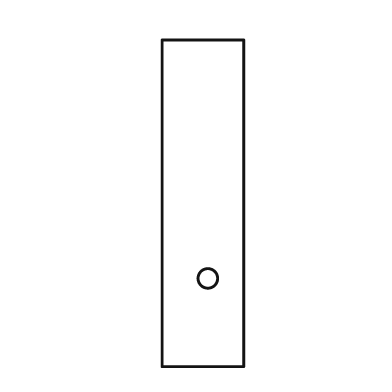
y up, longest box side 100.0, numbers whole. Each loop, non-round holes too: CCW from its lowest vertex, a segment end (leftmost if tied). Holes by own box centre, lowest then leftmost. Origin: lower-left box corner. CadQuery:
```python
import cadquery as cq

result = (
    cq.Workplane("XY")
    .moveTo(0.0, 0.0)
    .lineTo(25.0, 0.0)
    .lineTo(25.0, 100.0)
    .lineTo(0.0, 100.0)
    .close()
    .moveTo(14.0, 27.0)
    .circle(3.0)
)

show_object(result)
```